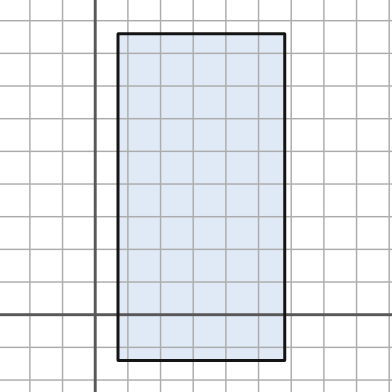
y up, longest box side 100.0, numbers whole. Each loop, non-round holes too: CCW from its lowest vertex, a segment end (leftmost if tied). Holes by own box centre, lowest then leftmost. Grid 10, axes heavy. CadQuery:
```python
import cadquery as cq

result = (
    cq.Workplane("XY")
    .moveTo(7.0, -14.0)
    .lineTo(58.0, -14.0)
    .lineTo(58.0, 86.0)
    .lineTo(7.0, 86.0)
    .close()
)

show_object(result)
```